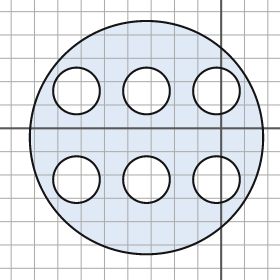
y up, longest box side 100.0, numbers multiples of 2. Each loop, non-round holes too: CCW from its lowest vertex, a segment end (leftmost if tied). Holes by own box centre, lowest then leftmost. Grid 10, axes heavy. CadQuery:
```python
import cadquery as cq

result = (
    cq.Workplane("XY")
    .moveTo(-32.0, -4.0)
    .circle(50.0)
    .moveTo(-62.0, -22.0)
    .circle(10.0)
    .moveTo(-32.0, -22.0)
    .circle(10.0)
    .moveTo(-2.0, -22.0)
    .circle(10.0)
    .moveTo(-62.0, 16.0)
    .circle(10.0)
    .moveTo(-32.0, 16.0)
    .circle(10.0)
    .moveTo(-2.0, 16.0)
    .circle(10.0)
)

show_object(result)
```